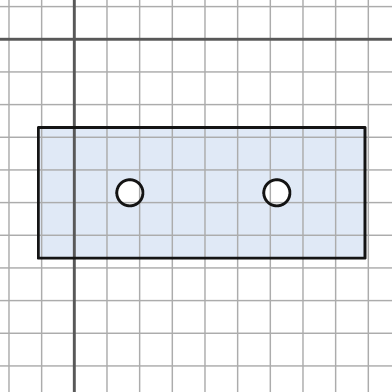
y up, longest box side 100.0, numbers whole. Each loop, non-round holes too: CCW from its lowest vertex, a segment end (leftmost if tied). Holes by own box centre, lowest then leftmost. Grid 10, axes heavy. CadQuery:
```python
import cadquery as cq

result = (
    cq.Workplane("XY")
    .moveTo(-11.0, -67.0)
    .lineTo(89.0, -67.0)
    .lineTo(89.0, -27.0)
    .lineTo(-11.0, -27.0)
    .close()
    .moveTo(17.0, -47.0)
    .circle(4.0)
    .moveTo(62.0, -47.0)
    .circle(4.0)
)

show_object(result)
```